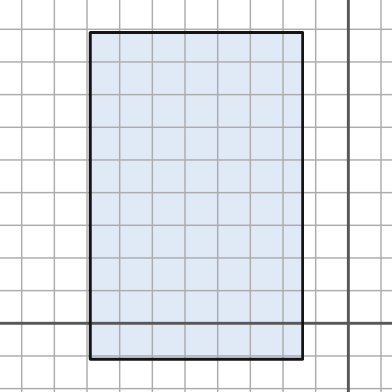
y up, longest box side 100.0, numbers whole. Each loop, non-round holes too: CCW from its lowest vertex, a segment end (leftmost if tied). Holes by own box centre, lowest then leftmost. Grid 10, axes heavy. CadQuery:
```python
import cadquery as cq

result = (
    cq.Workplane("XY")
    .moveTo(-79.0, -11.0)
    .lineTo(-14.0, -11.0)
    .lineTo(-14.0, 89.0)
    .lineTo(-79.0, 89.0)
    .close()
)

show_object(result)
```